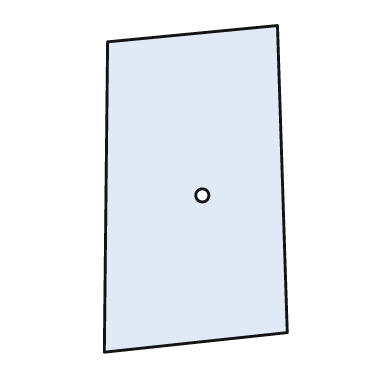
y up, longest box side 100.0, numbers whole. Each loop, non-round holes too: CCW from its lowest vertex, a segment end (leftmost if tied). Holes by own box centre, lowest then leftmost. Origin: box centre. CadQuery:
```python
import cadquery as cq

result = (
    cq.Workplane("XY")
    .moveTo(-28.0, -50.0)
    .lineTo(28.0, -44.0)
    .lineTo(25.0, 50.0)
    .lineTo(-27.0, 45.0)
    .close()
    .moveTo(2.0, -2.0)
    .circle(2.0)
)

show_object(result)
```